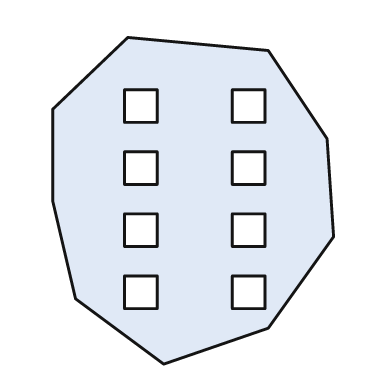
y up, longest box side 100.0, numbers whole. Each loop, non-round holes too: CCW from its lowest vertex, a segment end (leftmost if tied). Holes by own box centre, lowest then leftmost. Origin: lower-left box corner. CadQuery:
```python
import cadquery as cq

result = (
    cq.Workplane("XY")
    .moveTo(34.0, 0.0)
    .lineTo(66.0, 11.0)
    .lineTo(86.0, 39.0)
    .lineTo(84.0, 69.0)
    .lineTo(66.0, 96.0)
    .lineTo(23.0, 100.0)
    .lineTo(0.0, 78.0)
    .lineTo(0.0, 50.0)
    .lineTo(7.0, 20.0)
    .close()
    .moveTo(22.0, 17.0)
    .lineTo(32.0, 17.0)
    .lineTo(32.0, 27.0)
    .lineTo(22.0, 27.0)
    .close()
    .moveTo(55.0, 17.0)
    .lineTo(65.0, 17.0)
    .lineTo(65.0, 27.0)
    .lineTo(55.0, 27.0)
    .close()
    .moveTo(22.0, 36.0)
    .lineTo(32.0, 36.0)
    .lineTo(32.0, 46.0)
    .lineTo(22.0, 46.0)
    .close()
    .moveTo(55.0, 36.0)
    .lineTo(65.0, 36.0)
    .lineTo(65.0, 46.0)
    .lineTo(55.0, 46.0)
    .close()
    .moveTo(22.0, 55.0)
    .lineTo(32.0, 55.0)
    .lineTo(32.0, 65.0)
    .lineTo(22.0, 65.0)
    .close()
    .moveTo(55.0, 55.0)
    .lineTo(65.0, 55.0)
    .lineTo(65.0, 65.0)
    .lineTo(55.0, 65.0)
    .close()
    .moveTo(22.0, 74.0)
    .lineTo(32.0, 74.0)
    .lineTo(32.0, 84.0)
    .lineTo(22.0, 84.0)
    .close()
    .moveTo(55.0, 74.0)
    .lineTo(65.0, 74.0)
    .lineTo(65.0, 84.0)
    .lineTo(55.0, 84.0)
    .close()
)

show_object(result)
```